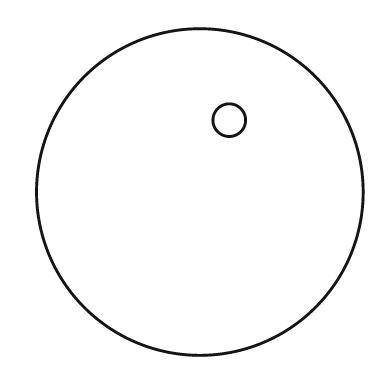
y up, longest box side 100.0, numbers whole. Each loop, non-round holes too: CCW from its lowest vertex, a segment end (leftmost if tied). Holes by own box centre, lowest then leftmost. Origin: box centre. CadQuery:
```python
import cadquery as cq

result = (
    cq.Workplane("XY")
    .moveTo(0.0, 0.0)
    .circle(50.0)
    .moveTo(9.0, 22.0)
    .circle(5.0)
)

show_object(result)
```